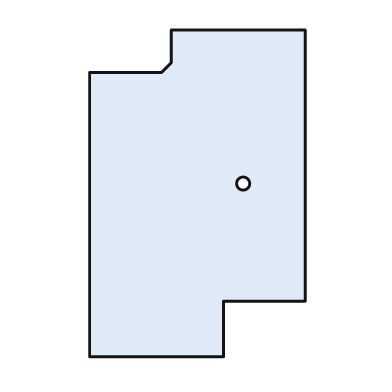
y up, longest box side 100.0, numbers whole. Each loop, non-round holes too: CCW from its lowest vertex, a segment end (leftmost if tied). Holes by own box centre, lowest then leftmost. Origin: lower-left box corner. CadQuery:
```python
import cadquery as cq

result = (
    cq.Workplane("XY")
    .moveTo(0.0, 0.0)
    .lineTo(41.0, 0.0)
    .lineTo(41.0, 17.0)
    .lineTo(66.0, 17.0)
    .lineTo(66.0, 100.0)
    .lineTo(25.0, 100.0)
    .lineTo(25.0, 90.0)
    .lineTo(22.0, 87.0)
    .lineTo(0.0, 87.0)
    .close()
    .moveTo(47.0, 53.0)
    .circle(2.0)
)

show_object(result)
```